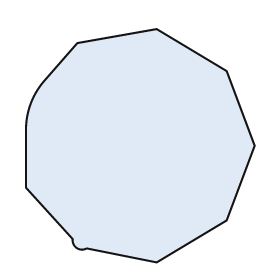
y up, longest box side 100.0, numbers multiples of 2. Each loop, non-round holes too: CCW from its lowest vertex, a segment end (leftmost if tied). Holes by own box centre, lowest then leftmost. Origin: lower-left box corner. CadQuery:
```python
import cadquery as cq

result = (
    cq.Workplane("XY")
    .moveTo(56.0, 0.0)
    .lineTo(86.0, 18.0)
    .lineTo(98.0, 50.0)
    .lineTo(86.0, 82.0)
    .lineTo(56.0, 100.0)
    .lineTo(22.0, 94.0)
    .lineTo(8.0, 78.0)
    .threePointArc((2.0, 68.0), (0.0, 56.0))
    .lineTo(0.0, 32.0)
    .lineTo(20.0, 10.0)
    .threePointArc((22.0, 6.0), (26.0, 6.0))
    .close()
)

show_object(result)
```